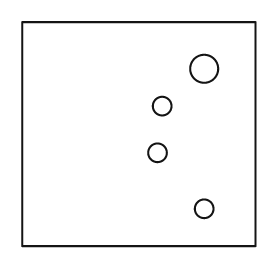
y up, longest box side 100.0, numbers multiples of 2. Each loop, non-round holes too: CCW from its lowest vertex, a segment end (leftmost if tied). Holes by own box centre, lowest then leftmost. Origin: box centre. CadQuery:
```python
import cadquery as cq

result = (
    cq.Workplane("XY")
    .moveTo(-50.0, -48.0)
    .lineTo(50.0, -48.0)
    .lineTo(50.0, 48.0)
    .lineTo(-50.0, 48.0)
    .close()
    .moveTo(28.0, -32.0)
    .circle(4.0)
    .moveTo(8.0, -8.0)
    .circle(4.0)
    .moveTo(10.0, 12.0)
    .circle(4.0)
    .moveTo(28.0, 28.0)
    .circle(6.0)
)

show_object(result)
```